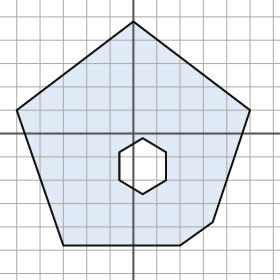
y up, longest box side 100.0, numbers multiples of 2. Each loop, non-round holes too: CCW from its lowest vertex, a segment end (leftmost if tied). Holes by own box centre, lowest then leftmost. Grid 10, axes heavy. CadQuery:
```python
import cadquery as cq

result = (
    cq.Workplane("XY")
    .moveTo(-30.0, -48.0)
    .lineTo(20.0, -48.0)
    .lineTo(34.0, -38.0)
    .lineTo(50.0, 10.0)
    .lineTo(0.0, 48.0)
    .lineTo(-50.0, 10.0)
    .close()
    .moveTo(4.0, -26.0)
    .lineTo(14.0, -20.0)
    .lineTo(14.0, -8.0)
    .lineTo(4.0, -2.0)
    .lineTo(-6.0, -8.0)
    .lineTo(-6.0, -20.0)
    .close()
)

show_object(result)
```